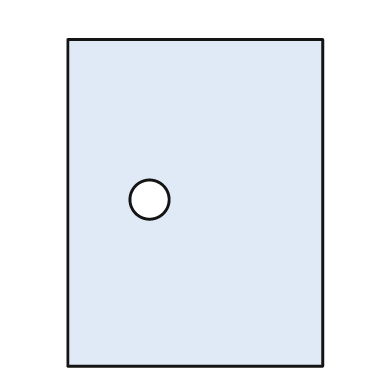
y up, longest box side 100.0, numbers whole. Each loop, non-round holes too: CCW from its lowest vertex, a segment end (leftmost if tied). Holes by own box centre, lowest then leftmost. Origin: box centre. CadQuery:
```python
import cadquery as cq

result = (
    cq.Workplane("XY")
    .moveTo(-39.0, -50.0)
    .lineTo(39.0, -50.0)
    .lineTo(39.0, 50.0)
    .lineTo(-39.0, 50.0)
    .close()
    .moveTo(-14.0, 1.0)
    .circle(6.0)
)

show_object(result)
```